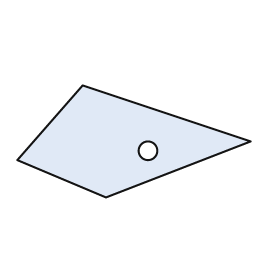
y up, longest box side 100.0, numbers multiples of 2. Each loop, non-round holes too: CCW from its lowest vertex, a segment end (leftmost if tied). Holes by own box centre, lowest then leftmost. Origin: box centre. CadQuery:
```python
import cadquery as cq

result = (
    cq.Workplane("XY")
    .moveTo(-12.0, -24.0)
    .lineTo(50.0, 0.0)
    .lineTo(-22.0, 24.0)
    .lineTo(-50.0, -8.0)
    .close()
    .moveTo(6.0, -4.0)
    .circle(4.0)
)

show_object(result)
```